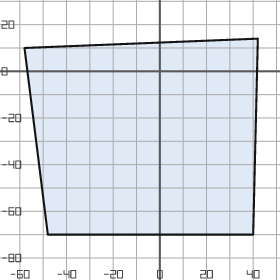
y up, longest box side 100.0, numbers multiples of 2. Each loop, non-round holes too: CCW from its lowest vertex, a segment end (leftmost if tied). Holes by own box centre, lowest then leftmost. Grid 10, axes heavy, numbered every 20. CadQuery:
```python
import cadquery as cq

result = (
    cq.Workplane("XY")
    .moveTo(-48.0, -70.0)
    .lineTo(40.0, -70.0)
    .lineTo(42.0, 14.0)
    .lineTo(-58.0, 10.0)
    .close()
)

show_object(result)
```